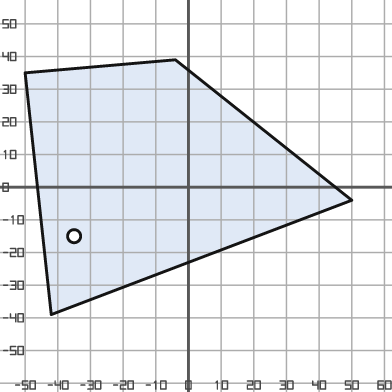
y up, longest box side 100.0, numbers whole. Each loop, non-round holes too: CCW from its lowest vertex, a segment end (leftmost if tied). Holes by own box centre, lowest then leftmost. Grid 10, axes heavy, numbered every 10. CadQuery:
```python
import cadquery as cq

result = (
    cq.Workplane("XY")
    .moveTo(-42.0, -39.0)
    .lineTo(50.0, -4.0)
    .lineTo(-4.0, 39.0)
    .lineTo(-50.0, 35.0)
    .close()
    .moveTo(-35.0, -15.0)
    .circle(2.0)
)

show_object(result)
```